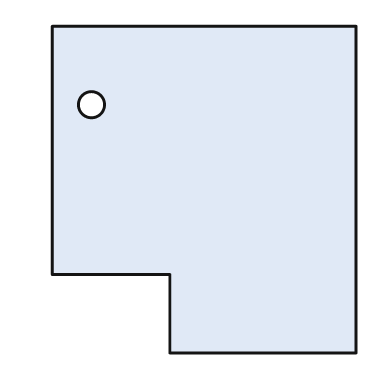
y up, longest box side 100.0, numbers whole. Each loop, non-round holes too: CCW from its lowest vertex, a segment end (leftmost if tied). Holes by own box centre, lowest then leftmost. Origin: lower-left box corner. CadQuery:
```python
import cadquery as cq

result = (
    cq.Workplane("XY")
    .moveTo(36.0, 0.0)
    .lineTo(93.0, 0.0)
    .lineTo(93.0, 100.0)
    .lineTo(0.0, 100.0)
    .lineTo(0.0, 24.0)
    .lineTo(36.0, 24.0)
    .close()
    .moveTo(12.0, 76.0)
    .circle(4.0)
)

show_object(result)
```